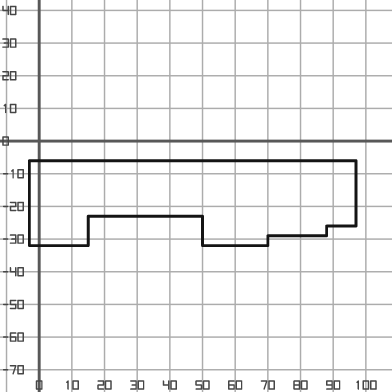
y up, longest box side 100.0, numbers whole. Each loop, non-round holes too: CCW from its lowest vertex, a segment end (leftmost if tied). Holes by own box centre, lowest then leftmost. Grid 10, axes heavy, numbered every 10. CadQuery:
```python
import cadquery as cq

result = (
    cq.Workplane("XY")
    .moveTo(-3.0, -32.0)
    .lineTo(15.0, -32.0)
    .lineTo(15.0, -23.0)
    .lineTo(50.0, -23.0)
    .lineTo(50.0, -32.0)
    .lineTo(70.0, -32.0)
    .lineTo(70.0, -29.0)
    .lineTo(88.0, -29.0)
    .lineTo(88.0, -26.0)
    .lineTo(97.0, -26.0)
    .lineTo(97.0, -6.0)
    .lineTo(-3.0, -6.0)
    .close()
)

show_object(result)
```